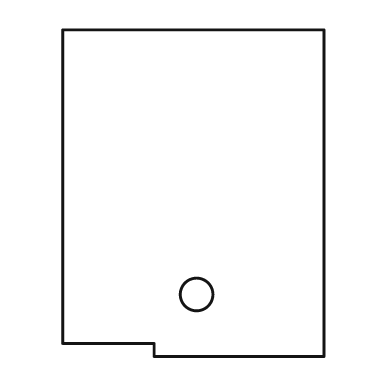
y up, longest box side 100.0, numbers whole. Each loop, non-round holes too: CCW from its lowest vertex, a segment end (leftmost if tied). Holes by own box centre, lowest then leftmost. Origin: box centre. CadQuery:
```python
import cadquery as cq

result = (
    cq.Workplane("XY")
    .moveTo(-12.0, -50.0)
    .lineTo(40.0, -50.0)
    .lineTo(40.0, 50.0)
    .lineTo(-40.0, 50.0)
    .lineTo(-40.0, -46.0)
    .lineTo(-12.0, -46.0)
    .close()
    .moveTo(1.0, -31.0)
    .circle(5.0)
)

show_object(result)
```